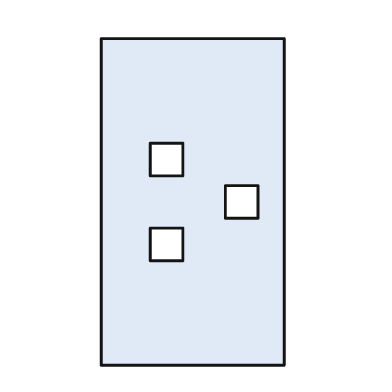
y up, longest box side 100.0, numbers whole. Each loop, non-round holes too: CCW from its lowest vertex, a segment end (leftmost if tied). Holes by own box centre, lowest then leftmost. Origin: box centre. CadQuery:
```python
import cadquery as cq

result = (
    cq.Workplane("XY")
    .moveTo(-28.0, -50.0)
    .lineTo(28.0, -50.0)
    .lineTo(28.0, 50.0)
    .lineTo(-28.0, 50.0)
    .close()
    .moveTo(-13.0, -18.0)
    .lineTo(-3.0, -18.0)
    .lineTo(-3.0, -8.0)
    .lineTo(-13.0, -8.0)
    .close()
    .moveTo(10.0, -5.0)
    .lineTo(20.0, -5.0)
    .lineTo(20.0, 5.0)
    .lineTo(10.0, 5.0)
    .close()
    .moveTo(-13.0, 8.0)
    .lineTo(-3.0, 8.0)
    .lineTo(-3.0, 18.0)
    .lineTo(-13.0, 18.0)
    .close()
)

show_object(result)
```